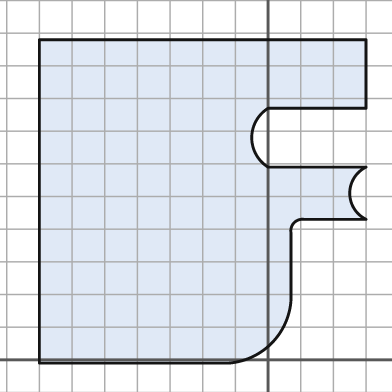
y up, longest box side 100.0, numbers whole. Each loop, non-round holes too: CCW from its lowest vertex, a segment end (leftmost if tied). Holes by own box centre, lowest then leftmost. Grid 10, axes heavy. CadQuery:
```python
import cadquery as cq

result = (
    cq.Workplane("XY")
    .moveTo(-70.0, -1.0)
    .lineTo(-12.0, -1.0)
    .threePointArc((1.0, 5.0), (7.0, 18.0))
    .lineTo(7.0, 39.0)
    .threePointArc((8.0, 42.0), (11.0, 43.0))
    .lineTo(30.0, 43.0)
    .threePointArc((25.0, 51.0), (30.0, 59.0))
    .lineTo(0.0, 59.0)
    .threePointArc((-5.0, 68.0), (0.0, 77.0))
    .lineTo(30.0, 77.0)
    .lineTo(30.0, 98.0)
    .lineTo(-70.0, 98.0)
    .close()
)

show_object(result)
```